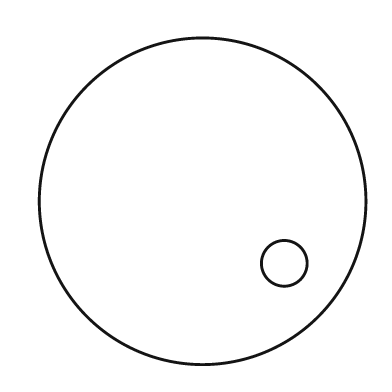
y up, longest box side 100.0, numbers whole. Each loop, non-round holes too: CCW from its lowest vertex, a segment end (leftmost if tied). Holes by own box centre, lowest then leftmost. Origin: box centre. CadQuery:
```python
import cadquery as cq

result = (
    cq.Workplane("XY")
    .moveTo(0.0, 0.0)
    .circle(50.0)
    .moveTo(25.0, -19.0)
    .circle(7.0)
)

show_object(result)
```